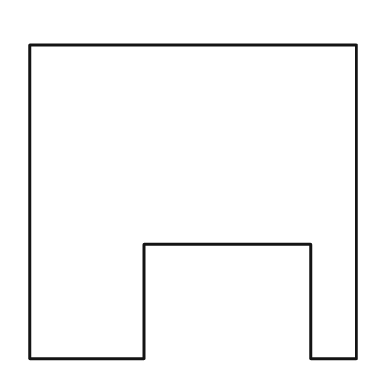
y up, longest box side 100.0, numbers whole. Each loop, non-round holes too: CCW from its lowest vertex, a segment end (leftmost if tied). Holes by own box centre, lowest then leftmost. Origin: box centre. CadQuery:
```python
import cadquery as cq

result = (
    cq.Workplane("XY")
    .moveTo(-50.0, -48.0)
    .lineTo(-15.0, -48.0)
    .lineTo(-15.0, -13.0)
    .lineTo(36.0, -13.0)
    .lineTo(36.0, -48.0)
    .lineTo(50.0, -48.0)
    .lineTo(50.0, 48.0)
    .lineTo(-50.0, 48.0)
    .close()
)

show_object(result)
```